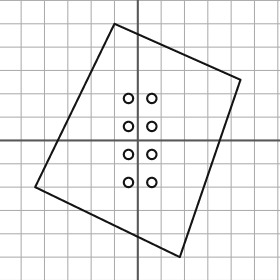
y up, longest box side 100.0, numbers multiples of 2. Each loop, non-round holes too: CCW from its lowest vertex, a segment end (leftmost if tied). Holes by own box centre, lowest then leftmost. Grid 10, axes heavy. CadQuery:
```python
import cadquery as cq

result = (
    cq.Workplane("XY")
    .moveTo(18.0, -50.0)
    .lineTo(44.0, 26.0)
    .lineTo(-10.0, 50.0)
    .lineTo(-44.0, -20.0)
    .close()
    .moveTo(-4.0, -18.0)
    .circle(2.0)
    .moveTo(6.0, -18.0)
    .circle(2.0)
    .moveTo(-4.0, -6.0)
    .circle(2.0)
    .moveTo(6.0, -6.0)
    .circle(2.0)
    .moveTo(-4.0, 6.0)
    .circle(2.0)
    .moveTo(6.0, 6.0)
    .circle(2.0)
    .moveTo(-4.0, 18.0)
    .circle(2.0)
    .moveTo(6.0, 18.0)
    .circle(2.0)
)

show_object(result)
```